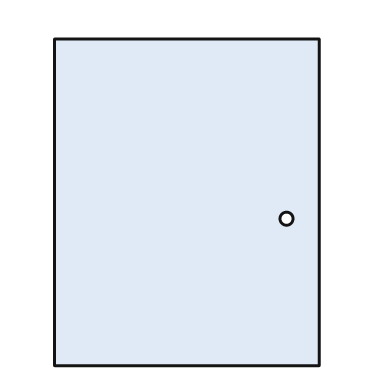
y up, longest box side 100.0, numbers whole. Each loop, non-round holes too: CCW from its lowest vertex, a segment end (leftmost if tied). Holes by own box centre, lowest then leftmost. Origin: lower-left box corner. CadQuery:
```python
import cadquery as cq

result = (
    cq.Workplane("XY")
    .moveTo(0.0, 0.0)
    .lineTo(81.0, 0.0)
    .lineTo(81.0, 100.0)
    .lineTo(0.0, 100.0)
    .close()
    .moveTo(71.0, 45.0)
    .circle(2.0)
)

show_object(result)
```